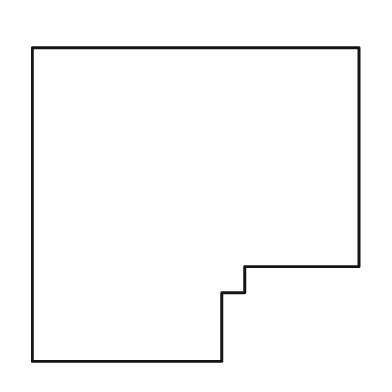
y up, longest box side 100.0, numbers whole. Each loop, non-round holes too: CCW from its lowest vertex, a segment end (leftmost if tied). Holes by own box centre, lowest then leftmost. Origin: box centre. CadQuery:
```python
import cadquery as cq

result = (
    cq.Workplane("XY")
    .moveTo(-50.0, -48.0)
    .lineTo(8.0, -48.0)
    .lineTo(8.0, -27.0)
    .lineTo(15.0, -27.0)
    .lineTo(15.0, -19.0)
    .lineTo(50.0, -19.0)
    .lineTo(50.0, 48.0)
    .lineTo(-50.0, 48.0)
    .close()
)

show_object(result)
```